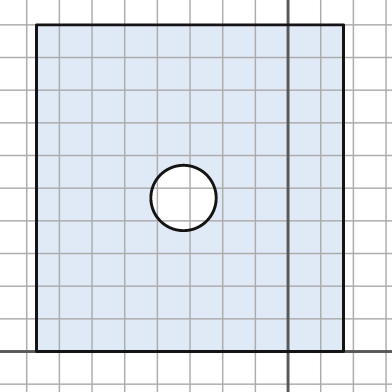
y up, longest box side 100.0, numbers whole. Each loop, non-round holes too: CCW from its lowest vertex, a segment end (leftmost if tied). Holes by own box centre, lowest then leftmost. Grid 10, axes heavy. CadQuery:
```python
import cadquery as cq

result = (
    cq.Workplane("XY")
    .moveTo(-77.0, 0.0)
    .lineTo(17.0, 0.0)
    .lineTo(17.0, 100.0)
    .lineTo(-77.0, 100.0)
    .close()
    .moveTo(-32.0, 47.0)
    .circle(10.0)
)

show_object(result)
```